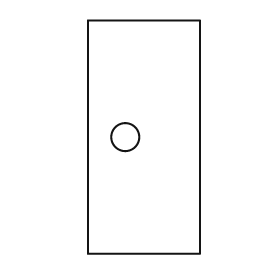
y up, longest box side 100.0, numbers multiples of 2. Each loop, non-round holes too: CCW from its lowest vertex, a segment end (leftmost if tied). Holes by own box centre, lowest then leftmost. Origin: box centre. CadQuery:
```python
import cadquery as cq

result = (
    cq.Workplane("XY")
    .moveTo(-24.0, -50.0)
    .lineTo(24.0, -50.0)
    .lineTo(24.0, 50.0)
    .lineTo(-24.0, 50.0)
    .close()
    .moveTo(-8.0, 0.0)
    .circle(6.0)
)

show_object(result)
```